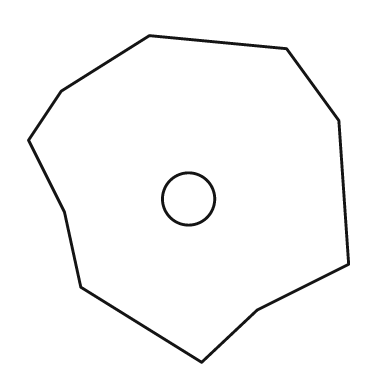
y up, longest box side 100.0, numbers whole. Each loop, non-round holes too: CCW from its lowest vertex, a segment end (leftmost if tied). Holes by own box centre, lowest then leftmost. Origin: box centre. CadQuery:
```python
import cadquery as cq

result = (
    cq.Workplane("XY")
    .moveTo(4.0, -50.0)
    .lineTo(21.0, -34.0)
    .lineTo(49.0, -20.0)
    .lineTo(46.0, 24.0)
    .lineTo(30.0, 46.0)
    .lineTo(-12.0, 50.0)
    .lineTo(-39.0, 33.0)
    .lineTo(-49.0, 18.0)
    .lineTo(-38.0, -4.0)
    .lineTo(-33.0, -27.0)
    .close()
    .moveTo(0.0, 0.0)
    .circle(8.0)
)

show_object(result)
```